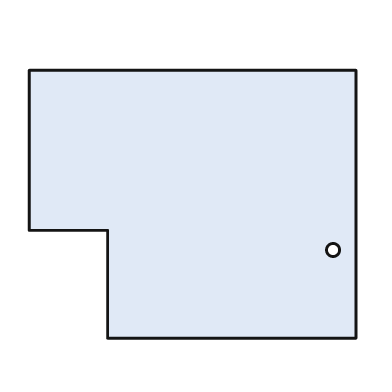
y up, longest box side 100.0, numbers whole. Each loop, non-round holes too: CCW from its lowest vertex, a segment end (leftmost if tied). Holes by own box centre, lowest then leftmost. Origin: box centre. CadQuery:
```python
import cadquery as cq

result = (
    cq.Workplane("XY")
    .moveTo(-26.0, -41.0)
    .lineTo(50.0, -41.0)
    .lineTo(50.0, 41.0)
    .lineTo(-50.0, 41.0)
    .lineTo(-50.0, -8.0)
    .lineTo(-26.0, -8.0)
    .close()
    .moveTo(43.0, -14.0)
    .circle(2.0)
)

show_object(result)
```